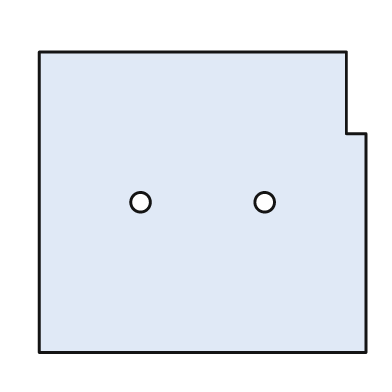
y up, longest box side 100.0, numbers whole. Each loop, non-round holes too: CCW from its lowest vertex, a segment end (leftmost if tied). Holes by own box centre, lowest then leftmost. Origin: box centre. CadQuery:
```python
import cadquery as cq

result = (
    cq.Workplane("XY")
    .moveTo(-50.0, -46.0)
    .lineTo(50.0, -46.0)
    .lineTo(50.0, 21.0)
    .lineTo(44.0, 21.0)
    .lineTo(44.0, 46.0)
    .lineTo(-50.0, 46.0)
    .close()
    .moveTo(-19.0, 0.0)
    .circle(3.0)
    .moveTo(19.0, 0.0)
    .circle(3.0)
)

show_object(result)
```